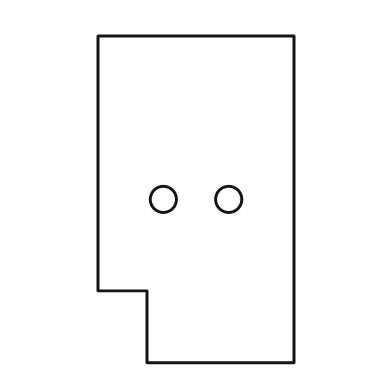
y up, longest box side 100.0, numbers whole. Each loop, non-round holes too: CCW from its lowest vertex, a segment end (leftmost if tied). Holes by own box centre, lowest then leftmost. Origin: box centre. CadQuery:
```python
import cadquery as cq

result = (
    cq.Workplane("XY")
    .moveTo(-15.0, -50.0)
    .lineTo(30.0, -50.0)
    .lineTo(30.0, 50.0)
    .lineTo(-30.0, 50.0)
    .lineTo(-30.0, -28.0)
    .lineTo(-15.0, -28.0)
    .close()
    .moveTo(-10.0, 0.0)
    .circle(4.0)
    .moveTo(10.0, 0.0)
    .circle(4.0)
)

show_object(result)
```